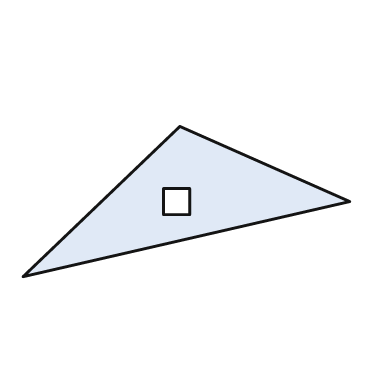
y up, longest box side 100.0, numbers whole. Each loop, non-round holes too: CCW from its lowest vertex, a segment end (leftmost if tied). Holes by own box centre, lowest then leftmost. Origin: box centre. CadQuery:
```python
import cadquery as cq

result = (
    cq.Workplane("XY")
    .moveTo(-50.0, -23.0)
    .lineTo(50.0, 0.0)
    .lineTo(-2.0, 23.0)
    .close()
    .moveTo(-7.0, -4.0)
    .lineTo(1.0, -4.0)
    .lineTo(1.0, 4.0)
    .lineTo(-7.0, 4.0)
    .close()
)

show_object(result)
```